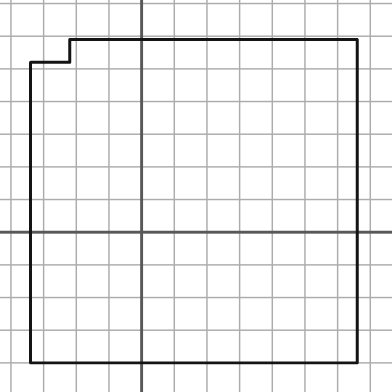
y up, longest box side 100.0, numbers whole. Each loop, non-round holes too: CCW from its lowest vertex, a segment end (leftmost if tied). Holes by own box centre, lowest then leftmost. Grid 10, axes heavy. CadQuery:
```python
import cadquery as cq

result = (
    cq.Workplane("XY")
    .moveTo(-34.0, -40.0)
    .lineTo(66.0, -40.0)
    .lineTo(66.0, 59.0)
    .lineTo(-22.0, 59.0)
    .lineTo(-22.0, 52.0)
    .lineTo(-34.0, 52.0)
    .close()
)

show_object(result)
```